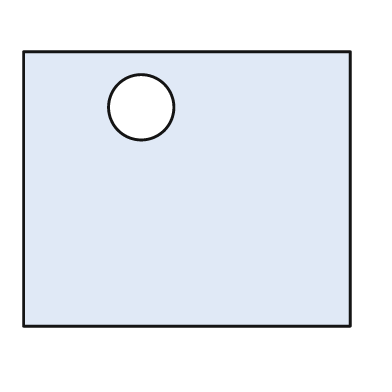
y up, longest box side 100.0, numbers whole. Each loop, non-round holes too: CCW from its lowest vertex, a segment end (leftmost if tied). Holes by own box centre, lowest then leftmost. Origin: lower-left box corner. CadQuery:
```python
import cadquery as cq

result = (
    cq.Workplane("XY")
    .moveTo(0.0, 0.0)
    .lineTo(100.0, 0.0)
    .lineTo(100.0, 84.0)
    .lineTo(0.0, 84.0)
    .close()
    .moveTo(36.0, 67.0)
    .circle(10.0)
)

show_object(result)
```